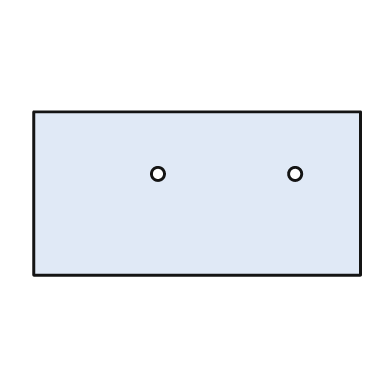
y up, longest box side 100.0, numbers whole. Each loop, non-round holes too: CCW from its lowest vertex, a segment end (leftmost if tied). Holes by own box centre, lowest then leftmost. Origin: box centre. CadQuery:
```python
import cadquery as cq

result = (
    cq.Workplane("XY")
    .moveTo(-50.0, -25.0)
    .lineTo(50.0, -25.0)
    .lineTo(50.0, 25.0)
    .lineTo(-50.0, 25.0)
    .close()
    .moveTo(-12.0, 6.0)
    .circle(2.0)
    .moveTo(30.0, 6.0)
    .circle(2.0)
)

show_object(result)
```